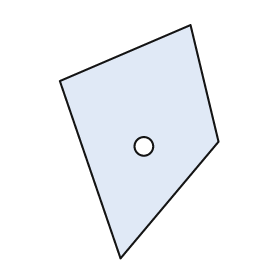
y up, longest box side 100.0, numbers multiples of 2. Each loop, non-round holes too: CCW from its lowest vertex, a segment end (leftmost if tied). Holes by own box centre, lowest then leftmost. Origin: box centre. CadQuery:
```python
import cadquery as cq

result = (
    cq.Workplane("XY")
    .moveTo(-8.0, -50.0)
    .lineTo(34.0, 0.0)
    .lineTo(22.0, 50.0)
    .lineTo(-34.0, 26.0)
    .close()
    .moveTo(2.0, -2.0)
    .circle(4.0)
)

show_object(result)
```